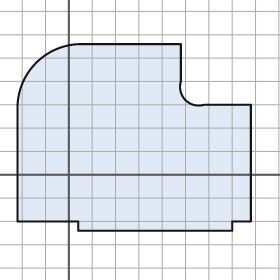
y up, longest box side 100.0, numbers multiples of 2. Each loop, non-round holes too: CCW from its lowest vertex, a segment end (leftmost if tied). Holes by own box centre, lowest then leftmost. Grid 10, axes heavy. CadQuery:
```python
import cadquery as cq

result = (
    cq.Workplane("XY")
    .moveTo(4.0, -24.0)
    .lineTo(70.0, -24.0)
    .lineTo(70.0, -20.0)
    .lineTo(78.0, -20.0)
    .lineTo(78.0, 30.0)
    .lineTo(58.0, 30.0)
    .threePointArc((50.0, 32.0), (48.0, 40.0))
    .lineTo(48.0, 56.0)
    .lineTo(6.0, 56.0)
    .threePointArc((-14.0, 48.0), (-22.0, 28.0))
    .lineTo(-22.0, -20.0)
    .lineTo(4.0, -20.0)
    .close()
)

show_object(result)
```